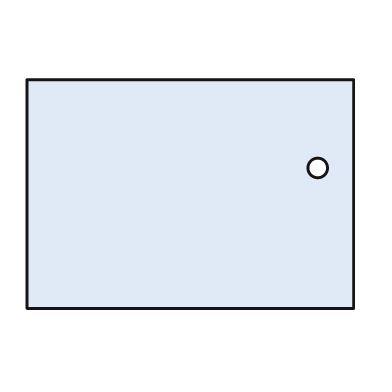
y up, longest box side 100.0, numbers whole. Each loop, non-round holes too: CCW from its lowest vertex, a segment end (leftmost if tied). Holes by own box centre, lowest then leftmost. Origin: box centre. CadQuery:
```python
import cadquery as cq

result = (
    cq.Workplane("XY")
    .moveTo(-50.0, -35.0)
    .lineTo(50.0, -35.0)
    .lineTo(50.0, 35.0)
    .lineTo(-50.0, 35.0)
    .close()
    .moveTo(39.0, 8.0)
    .circle(3.0)
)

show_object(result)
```